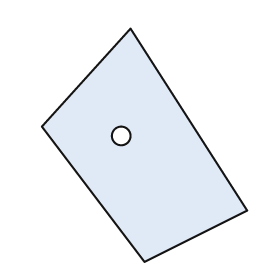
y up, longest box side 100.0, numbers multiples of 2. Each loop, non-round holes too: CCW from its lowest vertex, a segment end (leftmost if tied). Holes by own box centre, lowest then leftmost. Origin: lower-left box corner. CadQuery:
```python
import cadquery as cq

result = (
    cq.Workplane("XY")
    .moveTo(44.0, 0.0)
    .lineTo(88.0, 22.0)
    .lineTo(38.0, 100.0)
    .lineTo(0.0, 58.0)
    .close()
    .moveTo(34.0, 54.0)
    .circle(4.0)
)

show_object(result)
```